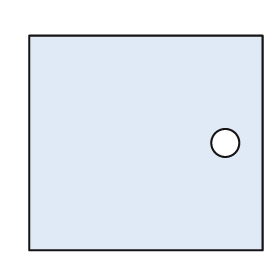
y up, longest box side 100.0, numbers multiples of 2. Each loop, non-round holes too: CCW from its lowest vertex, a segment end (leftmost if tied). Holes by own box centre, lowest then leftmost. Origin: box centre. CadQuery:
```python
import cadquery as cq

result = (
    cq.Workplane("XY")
    .moveTo(-50.0, -46.0)
    .lineTo(50.0, -46.0)
    .lineTo(50.0, 46.0)
    .lineTo(-50.0, 46.0)
    .close()
    .moveTo(34.0, 0.0)
    .circle(6.0)
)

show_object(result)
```